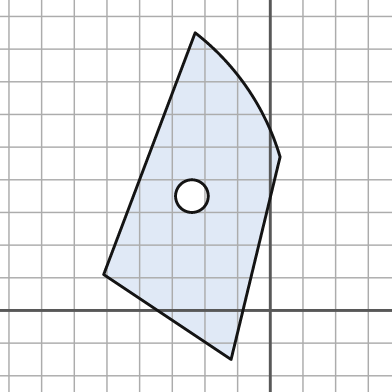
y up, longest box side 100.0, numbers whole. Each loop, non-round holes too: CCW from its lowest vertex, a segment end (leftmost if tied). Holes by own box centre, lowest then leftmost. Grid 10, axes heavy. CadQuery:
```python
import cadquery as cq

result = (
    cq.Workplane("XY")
    .moveTo(-12.0, -15.0)
    .lineTo(3.0, 47.0)
    .threePointArc((-7.0, 68.0), (-23.0, 85.0))
    .lineTo(-51.0, 11.0)
    .close()
    .moveTo(-24.0, 35.0)
    .circle(5.0)
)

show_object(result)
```